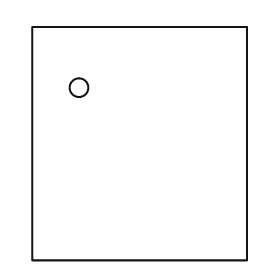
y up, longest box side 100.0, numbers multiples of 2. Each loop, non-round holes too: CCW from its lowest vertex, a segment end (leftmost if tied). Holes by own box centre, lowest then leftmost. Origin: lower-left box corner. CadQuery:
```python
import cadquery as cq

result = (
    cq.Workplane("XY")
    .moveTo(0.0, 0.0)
    .lineTo(92.0, 0.0)
    .lineTo(92.0, 100.0)
    .lineTo(0.0, 100.0)
    .close()
    .moveTo(20.0, 74.0)
    .circle(4.0)
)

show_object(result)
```